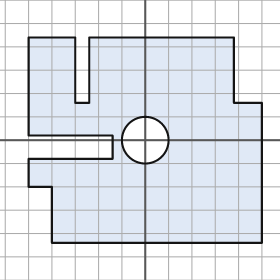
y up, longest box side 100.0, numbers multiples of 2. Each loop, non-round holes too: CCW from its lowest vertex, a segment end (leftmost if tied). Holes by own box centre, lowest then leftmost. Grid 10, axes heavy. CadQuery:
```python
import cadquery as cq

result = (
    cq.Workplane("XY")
    .moveTo(-40.0, -44.0)
    .lineTo(50.0, -44.0)
    .lineTo(50.0, 16.0)
    .lineTo(38.0, 16.0)
    .lineTo(38.0, 44.0)
    .lineTo(-24.0, 44.0)
    .lineTo(-24.0, 16.0)
    .lineTo(-30.0, 16.0)
    .lineTo(-30.0, 44.0)
    .lineTo(-50.0, 44.0)
    .lineTo(-50.0, 2.0)
    .lineTo(-14.0, 2.0)
    .lineTo(-14.0, -8.0)
    .lineTo(-50.0, -8.0)
    .lineTo(-50.0, -20.0)
    .lineTo(-40.0, -20.0)
    .close()
    .moveTo(0.0, 0.0)
    .circle(10.0)
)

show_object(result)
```